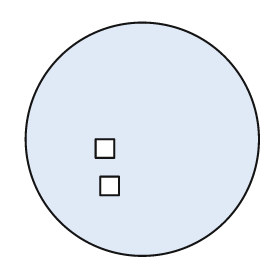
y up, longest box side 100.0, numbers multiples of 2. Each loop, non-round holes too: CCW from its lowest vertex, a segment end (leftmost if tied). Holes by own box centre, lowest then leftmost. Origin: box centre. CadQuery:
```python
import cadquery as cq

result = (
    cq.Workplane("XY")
    .moveTo(0.0, 0.0)
    .circle(50.0)
    .moveTo(-18.0, -24.0)
    .lineTo(-10.0, -24.0)
    .lineTo(-10.0, -16.0)
    .lineTo(-18.0, -16.0)
    .close()
    .moveTo(-20.0, -8.0)
    .lineTo(-12.0, -8.0)
    .lineTo(-12.0, 0.0)
    .lineTo(-20.0, 0.0)
    .close()
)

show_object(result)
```